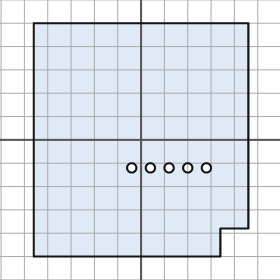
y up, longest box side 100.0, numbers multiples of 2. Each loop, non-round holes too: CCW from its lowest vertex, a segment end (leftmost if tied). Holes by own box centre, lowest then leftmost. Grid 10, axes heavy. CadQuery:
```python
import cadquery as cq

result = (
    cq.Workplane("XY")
    .moveTo(-46.0, -50.0)
    .lineTo(34.0, -50.0)
    .lineTo(34.0, -38.0)
    .lineTo(46.0, -38.0)
    .lineTo(46.0, 50.0)
    .lineTo(-46.0, 50.0)
    .close()
    .moveTo(-4.0, -12.0)
    .circle(2.0)
    .moveTo(4.0, -12.0)
    .circle(2.0)
    .moveTo(12.0, -12.0)
    .circle(2.0)
    .moveTo(20.0, -12.0)
    .circle(2.0)
    .moveTo(28.0, -12.0)
    .circle(2.0)
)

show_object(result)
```